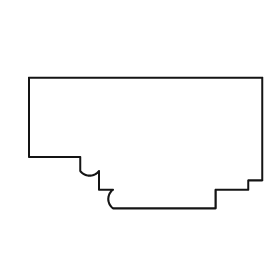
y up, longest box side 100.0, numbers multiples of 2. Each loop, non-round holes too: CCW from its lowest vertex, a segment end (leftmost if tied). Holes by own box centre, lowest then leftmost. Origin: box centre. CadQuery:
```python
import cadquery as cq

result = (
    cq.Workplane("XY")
    .moveTo(-14.0, -28.0)
    .lineTo(30.0, -28.0)
    .lineTo(30.0, -20.0)
    .lineTo(44.0, -20.0)
    .lineTo(44.0, -16.0)
    .lineTo(50.0, -16.0)
    .lineTo(50.0, 28.0)
    .lineTo(-50.0, 28.0)
    .lineTo(-50.0, -6.0)
    .lineTo(-28.0, -6.0)
    .lineTo(-28.0, -12.0)
    .threePointArc((-24.0, -14.0), (-20.0, -12.0))
    .lineTo(-20.0, -20.0)
    .lineTo(-14.0, -20.0)
    .threePointArc((-16.0, -24.0), (-14.0, -28.0))
    .close()
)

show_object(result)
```